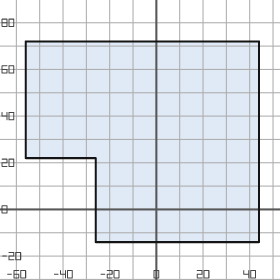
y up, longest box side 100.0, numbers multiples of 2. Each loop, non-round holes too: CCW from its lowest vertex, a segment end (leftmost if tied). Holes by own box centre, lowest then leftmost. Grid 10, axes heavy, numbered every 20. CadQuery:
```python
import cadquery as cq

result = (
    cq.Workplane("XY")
    .moveTo(-26.0, -14.0)
    .lineTo(44.0, -14.0)
    .lineTo(44.0, 72.0)
    .lineTo(-56.0, 72.0)
    .lineTo(-56.0, 22.0)
    .lineTo(-26.0, 22.0)
    .close()
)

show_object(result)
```